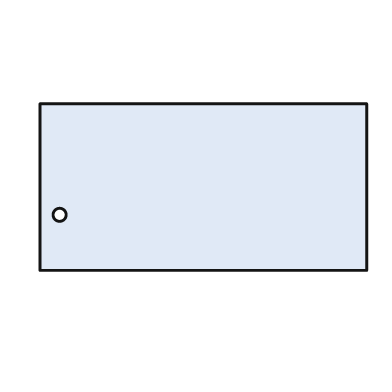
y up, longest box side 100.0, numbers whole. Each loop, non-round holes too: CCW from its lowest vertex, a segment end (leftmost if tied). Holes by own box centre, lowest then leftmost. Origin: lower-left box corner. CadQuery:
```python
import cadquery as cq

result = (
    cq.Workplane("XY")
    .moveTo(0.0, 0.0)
    .lineTo(100.0, 0.0)
    .lineTo(100.0, 51.0)
    .lineTo(0.0, 51.0)
    .close()
    .moveTo(6.0, 17.0)
    .circle(2.0)
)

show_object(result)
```